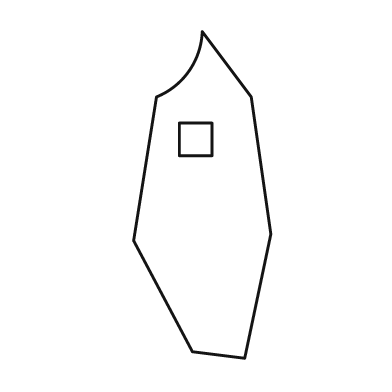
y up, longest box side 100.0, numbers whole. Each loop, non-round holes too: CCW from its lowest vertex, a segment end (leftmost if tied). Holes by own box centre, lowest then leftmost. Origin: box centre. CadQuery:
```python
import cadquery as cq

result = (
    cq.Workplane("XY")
    .moveTo(13.0, -50.0)
    .lineTo(21.0, -12.0)
    .lineTo(15.0, 30.0)
    .lineTo(0.0, 50.0)
    .threePointArc((-4.0, 38.0), (-14.0, 30.0))
    .lineTo(-21.0, -14.0)
    .lineTo(-3.0, -48.0)
    .close()
    .moveTo(-7.0, 12.0)
    .lineTo(3.0, 12.0)
    .lineTo(3.0, 22.0)
    .lineTo(-7.0, 22.0)
    .close()
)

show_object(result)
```